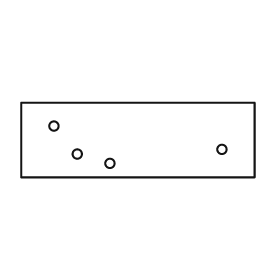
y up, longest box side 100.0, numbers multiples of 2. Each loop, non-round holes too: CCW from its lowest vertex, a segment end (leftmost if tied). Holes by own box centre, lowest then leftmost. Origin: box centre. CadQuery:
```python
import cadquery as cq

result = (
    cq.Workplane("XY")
    .moveTo(-50.0, -16.0)
    .lineTo(50.0, -16.0)
    .lineTo(50.0, 16.0)
    .lineTo(-50.0, 16.0)
    .close()
    .moveTo(-12.0, -10.0)
    .circle(2.0)
    .moveTo(-26.0, -6.0)
    .circle(2.0)
    .moveTo(36.0, -4.0)
    .circle(2.0)
    .moveTo(-36.0, 6.0)
    .circle(2.0)
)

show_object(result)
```